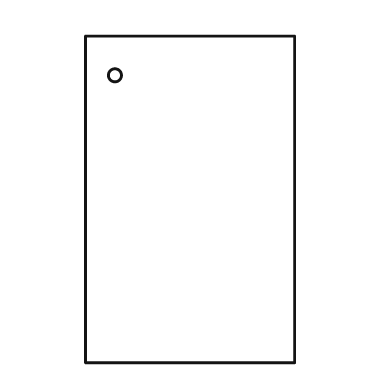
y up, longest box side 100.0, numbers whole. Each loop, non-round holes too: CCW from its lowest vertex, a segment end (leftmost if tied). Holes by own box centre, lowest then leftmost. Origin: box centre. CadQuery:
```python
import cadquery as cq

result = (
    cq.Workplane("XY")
    .moveTo(-32.0, -50.0)
    .lineTo(32.0, -50.0)
    .lineTo(32.0, 50.0)
    .lineTo(-32.0, 50.0)
    .close()
    .moveTo(-23.0, 38.0)
    .circle(2.0)
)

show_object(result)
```